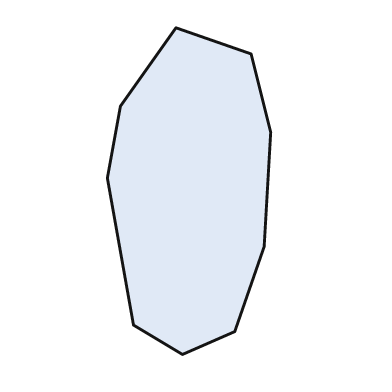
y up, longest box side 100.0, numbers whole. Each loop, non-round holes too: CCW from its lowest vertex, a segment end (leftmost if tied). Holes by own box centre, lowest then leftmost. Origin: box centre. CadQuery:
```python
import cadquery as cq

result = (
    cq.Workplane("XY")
    .moveTo(-2.0, -50.0)
    .lineTo(14.0, -43.0)
    .lineTo(23.0, -17.0)
    .lineTo(25.0, 18.0)
    .lineTo(19.0, 42.0)
    .lineTo(-4.0, 50.0)
    .lineTo(-21.0, 26.0)
    .lineTo(-25.0, 4.0)
    .lineTo(-17.0, -41.0)
    .close()
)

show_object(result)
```